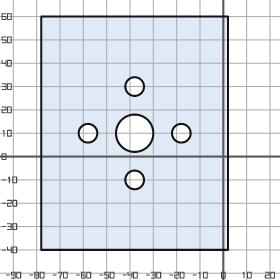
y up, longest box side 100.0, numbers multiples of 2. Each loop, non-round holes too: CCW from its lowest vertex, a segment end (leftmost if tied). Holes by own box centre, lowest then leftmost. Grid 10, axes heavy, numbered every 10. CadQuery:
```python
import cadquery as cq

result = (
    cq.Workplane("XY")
    .moveTo(-78.0, -40.0)
    .lineTo(2.0, -40.0)
    .lineTo(2.0, 60.0)
    .lineTo(-78.0, 60.0)
    .close()
    .moveTo(-38.0, -10.0)
    .circle(4.0)
    .moveTo(-58.0, 10.0)
    .circle(4.0)
    .moveTo(-38.0, 10.0)
    .circle(8.0)
    .moveTo(-18.0, 10.0)
    .circle(4.0)
    .moveTo(-38.0, 30.0)
    .circle(4.0)
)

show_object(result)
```